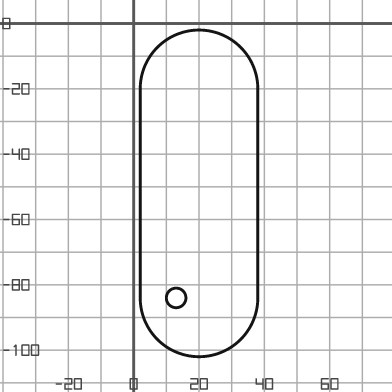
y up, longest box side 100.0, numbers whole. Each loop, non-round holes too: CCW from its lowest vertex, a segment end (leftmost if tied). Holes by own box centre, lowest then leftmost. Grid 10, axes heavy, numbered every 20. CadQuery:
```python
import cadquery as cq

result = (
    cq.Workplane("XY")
    .moveTo(2.0, -84.0)
    .threePointArc((20.0, -102.0), (38.0, -84.0))
    .lineTo(38.0, -20.0)
    .threePointArc((20.0, -2.0), (2.0, -20.0))
    .close()
    .moveTo(13.0, -84.0)
    .circle(3.0)
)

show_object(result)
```